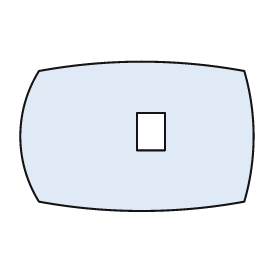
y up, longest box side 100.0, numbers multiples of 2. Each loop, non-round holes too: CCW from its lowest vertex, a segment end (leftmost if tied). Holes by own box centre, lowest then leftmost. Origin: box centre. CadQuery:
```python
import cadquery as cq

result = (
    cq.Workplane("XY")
    .moveTo(-42.0, -28.0)
    .threePointArc((2.0, -32.0), (46.0, -28.0))
    .threePointArc((50.0, 0.0), (46.0, 28.0))
    .threePointArc((2.0, 32.0), (-42.0, 28.0))
    .threePointArc((-50.0, 0.0), (-42.0, -28.0))
    .close()
    .moveTo(0.0, -6.0)
    .lineTo(12.0, -6.0)
    .lineTo(12.0, 10.0)
    .lineTo(0.0, 10.0)
    .close()
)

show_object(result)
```